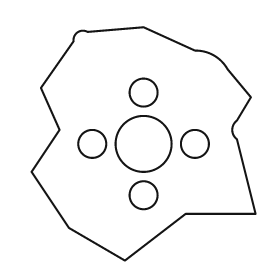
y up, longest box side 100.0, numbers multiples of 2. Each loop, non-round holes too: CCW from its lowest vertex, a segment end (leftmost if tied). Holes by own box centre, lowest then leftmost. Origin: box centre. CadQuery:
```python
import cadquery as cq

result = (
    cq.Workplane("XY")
    .moveTo(-8.0, -50.0)
    .lineTo(18.0, -30.0)
    .lineTo(48.0, -30.0)
    .lineTo(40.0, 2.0)
    .threePointArc((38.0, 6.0), (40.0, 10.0))
    .lineTo(46.0, 20.0)
    .lineTo(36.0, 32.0)
    .threePointArc((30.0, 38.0), (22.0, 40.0))
    .lineTo(0.0, 50.0)
    .lineTo(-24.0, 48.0)
    .threePointArc((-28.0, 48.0), (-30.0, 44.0))
    .lineTo(-44.0, 24.0)
    .lineTo(-36.0, 6.0)
    .lineTo(-48.0, -12.0)
    .lineTo(-32.0, -36.0)
    .close()
    .moveTo(0.0, -22.0)
    .circle(6.0)
    .moveTo(-22.0, 0.0)
    .circle(6.0)
    .moveTo(0.0, 0.0)
    .circle(12.0)
    .moveTo(22.0, 0.0)
    .circle(6.0)
    .moveTo(0.0, 22.0)
    .circle(6.0)
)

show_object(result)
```